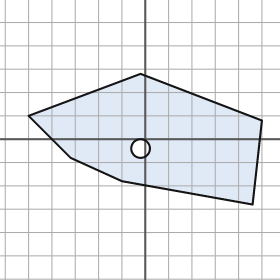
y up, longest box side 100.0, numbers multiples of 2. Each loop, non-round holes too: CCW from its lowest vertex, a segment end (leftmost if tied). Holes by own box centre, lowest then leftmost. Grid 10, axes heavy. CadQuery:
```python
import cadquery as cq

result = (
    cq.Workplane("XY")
    .moveTo(46.0, -28.0)
    .lineTo(50.0, 8.0)
    .lineTo(-2.0, 28.0)
    .lineTo(-50.0, 10.0)
    .lineTo(-32.0, -8.0)
    .lineTo(-10.0, -18.0)
    .close()
    .moveTo(-2.0, -4.0)
    .circle(4.0)
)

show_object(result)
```